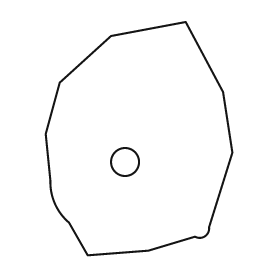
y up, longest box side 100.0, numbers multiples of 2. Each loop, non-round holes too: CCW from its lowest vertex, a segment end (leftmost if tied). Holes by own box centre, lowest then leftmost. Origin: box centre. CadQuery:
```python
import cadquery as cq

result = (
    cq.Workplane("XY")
    .moveTo(-22.0, -50.0)
    .lineTo(4.0, -48.0)
    .lineTo(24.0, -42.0)
    .threePointArc((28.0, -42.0), (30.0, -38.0))
    .lineTo(40.0, -6.0)
    .lineTo(36.0, 20.0)
    .lineTo(20.0, 50.0)
    .lineTo(-12.0, 44.0)
    .lineTo(-34.0, 24.0)
    .lineTo(-40.0, 2.0)
    .lineTo(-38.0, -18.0)
    .threePointArc((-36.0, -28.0), (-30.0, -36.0))
    .close()
    .moveTo(-6.0, -10.0)
    .circle(6.0)
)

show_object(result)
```